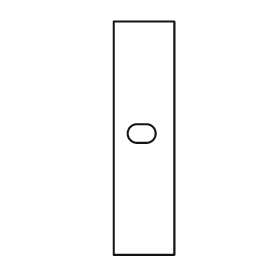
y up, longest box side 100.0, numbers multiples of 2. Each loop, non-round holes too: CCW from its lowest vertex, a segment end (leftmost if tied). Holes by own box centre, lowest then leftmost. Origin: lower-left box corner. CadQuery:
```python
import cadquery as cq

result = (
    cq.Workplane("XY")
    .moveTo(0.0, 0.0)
    .lineTo(26.0, 0.0)
    .lineTo(26.0, 100.0)
    .lineTo(0.0, 100.0)
    .close()
    .moveTo(10.0, 48.0)
    .lineTo(14.0, 48.0)
    .threePointArc((18.0, 52.0), (14.0, 56.0))
    .lineTo(10.0, 56.0)
    .threePointArc((6.0, 52.0), (10.0, 48.0))
    .close()
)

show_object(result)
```